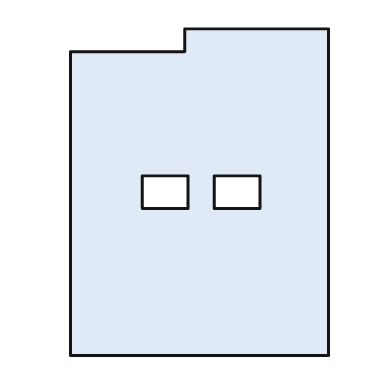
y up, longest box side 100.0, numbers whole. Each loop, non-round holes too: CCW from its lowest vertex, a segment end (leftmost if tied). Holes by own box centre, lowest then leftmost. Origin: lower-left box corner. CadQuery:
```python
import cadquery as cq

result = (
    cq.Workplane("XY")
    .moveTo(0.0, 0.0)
    .lineTo(79.0, 0.0)
    .lineTo(79.0, 100.0)
    .lineTo(35.0, 100.0)
    .lineTo(35.0, 93.0)
    .lineTo(0.0, 93.0)
    .close()
    .moveTo(22.0, 45.0)
    .lineTo(36.0, 45.0)
    .lineTo(36.0, 55.0)
    .lineTo(22.0, 55.0)
    .close()
    .moveTo(44.0, 45.0)
    .lineTo(58.0, 45.0)
    .lineTo(58.0, 55.0)
    .lineTo(44.0, 55.0)
    .close()
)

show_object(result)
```